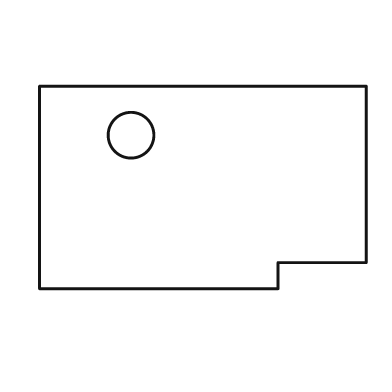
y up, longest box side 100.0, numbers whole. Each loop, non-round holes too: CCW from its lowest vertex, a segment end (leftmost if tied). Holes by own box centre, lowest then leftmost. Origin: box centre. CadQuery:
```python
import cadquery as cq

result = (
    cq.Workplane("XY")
    .moveTo(-50.0, -31.0)
    .lineTo(23.0, -31.0)
    .lineTo(23.0, -23.0)
    .lineTo(50.0, -23.0)
    .lineTo(50.0, 31.0)
    .lineTo(-50.0, 31.0)
    .close()
    .moveTo(-22.0, 16.0)
    .circle(7.0)
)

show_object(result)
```